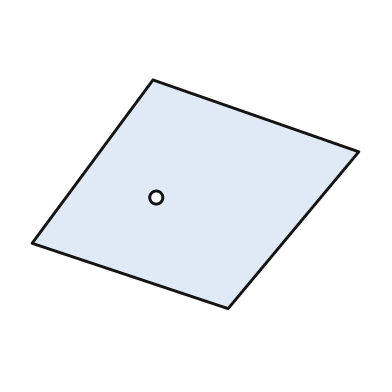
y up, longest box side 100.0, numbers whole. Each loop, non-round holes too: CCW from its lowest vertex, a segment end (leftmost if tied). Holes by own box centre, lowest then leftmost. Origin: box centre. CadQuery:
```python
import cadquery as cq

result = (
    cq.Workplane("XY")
    .moveTo(10.0, -35.0)
    .lineTo(50.0, 13.0)
    .lineTo(-13.0, 35.0)
    .lineTo(-50.0, -15.0)
    .close()
    .moveTo(-12.0, -1.0)
    .circle(2.0)
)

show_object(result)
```